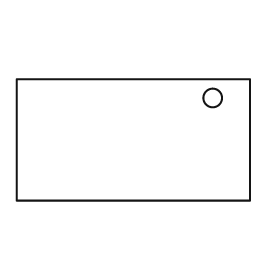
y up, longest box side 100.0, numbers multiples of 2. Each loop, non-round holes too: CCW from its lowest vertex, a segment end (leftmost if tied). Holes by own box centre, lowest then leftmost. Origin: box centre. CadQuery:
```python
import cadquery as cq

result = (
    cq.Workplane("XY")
    .moveTo(-50.0, -26.0)
    .lineTo(50.0, -26.0)
    .lineTo(50.0, 26.0)
    .lineTo(-50.0, 26.0)
    .close()
    .moveTo(34.0, 18.0)
    .circle(4.0)
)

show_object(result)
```